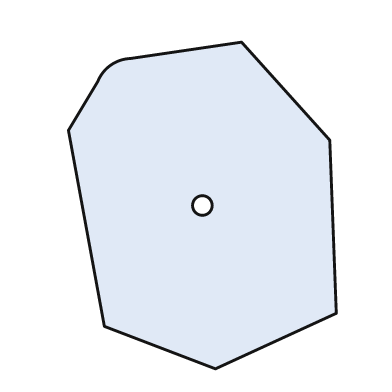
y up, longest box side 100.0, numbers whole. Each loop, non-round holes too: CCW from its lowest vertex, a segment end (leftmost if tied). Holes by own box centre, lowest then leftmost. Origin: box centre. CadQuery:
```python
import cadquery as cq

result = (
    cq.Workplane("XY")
    .moveTo(4.0, -50.0)
    .lineTo(41.0, -33.0)
    .lineTo(39.0, 20.0)
    .lineTo(12.0, 50.0)
    .lineTo(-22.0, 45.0)
    .threePointArc((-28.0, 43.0), (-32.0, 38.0))
    .lineTo(-41.0, 23.0)
    .lineTo(-30.0, -37.0)
    .close()
    .moveTo(0.0, 0.0)
    .circle(3.0)
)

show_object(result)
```